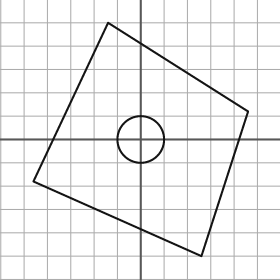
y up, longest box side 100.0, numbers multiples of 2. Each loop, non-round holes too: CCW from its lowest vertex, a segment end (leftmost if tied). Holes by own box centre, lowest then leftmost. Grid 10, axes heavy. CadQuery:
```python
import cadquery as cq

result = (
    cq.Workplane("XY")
    .moveTo(26.0, -50.0)
    .lineTo(46.0, 12.0)
    .lineTo(-14.0, 50.0)
    .lineTo(-46.0, -18.0)
    .close()
    .moveTo(0.0, 0.0)
    .circle(10.0)
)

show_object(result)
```